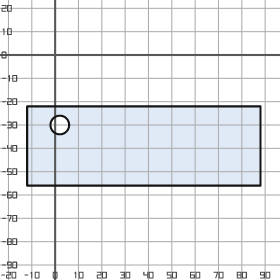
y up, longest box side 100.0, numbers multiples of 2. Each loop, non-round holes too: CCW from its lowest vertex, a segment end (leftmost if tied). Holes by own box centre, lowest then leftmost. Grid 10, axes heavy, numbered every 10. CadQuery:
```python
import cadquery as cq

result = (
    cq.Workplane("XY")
    .moveTo(-12.0, -56.0)
    .lineTo(88.0, -56.0)
    .lineTo(88.0, -22.0)
    .lineTo(-12.0, -22.0)
    .close()
    .moveTo(2.0, -30.0)
    .circle(4.0)
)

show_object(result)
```